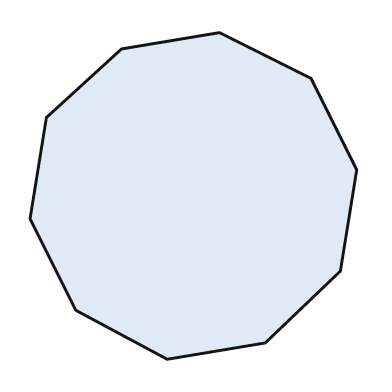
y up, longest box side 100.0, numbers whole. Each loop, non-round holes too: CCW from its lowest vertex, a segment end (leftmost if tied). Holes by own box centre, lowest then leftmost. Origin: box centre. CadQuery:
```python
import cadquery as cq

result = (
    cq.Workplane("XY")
    .moveTo(-8.0, -50.0)
    .lineTo(22.0, -45.0)
    .lineTo(45.0, -23.0)
    .lineTo(50.0, 8.0)
    .lineTo(36.0, 36.0)
    .lineTo(8.0, 50.0)
    .lineTo(-22.0, 45.0)
    .lineTo(-45.0, 24.0)
    .lineTo(-50.0, -7.0)
    .lineTo(-36.0, -35.0)
    .close()
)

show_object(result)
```